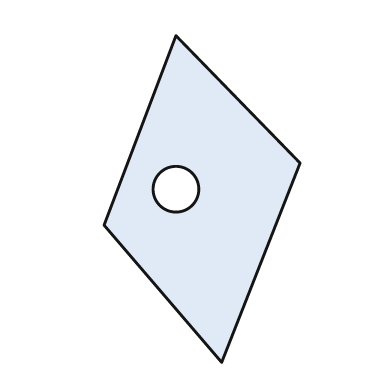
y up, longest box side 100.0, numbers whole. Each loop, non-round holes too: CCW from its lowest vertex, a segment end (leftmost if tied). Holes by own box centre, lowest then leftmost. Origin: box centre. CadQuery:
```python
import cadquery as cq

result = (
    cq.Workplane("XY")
    .moveTo(6.0, -50.0)
    .lineTo(30.0, 11.0)
    .lineTo(-8.0, 50.0)
    .lineTo(-30.0, -8.0)
    .close()
    .moveTo(-8.0, 3.0)
    .circle(7.0)
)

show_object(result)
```